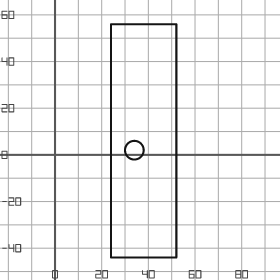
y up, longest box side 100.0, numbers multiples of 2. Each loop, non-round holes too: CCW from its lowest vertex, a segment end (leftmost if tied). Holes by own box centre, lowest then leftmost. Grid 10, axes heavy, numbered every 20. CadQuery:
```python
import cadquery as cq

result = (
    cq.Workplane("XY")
    .moveTo(24.0, -44.0)
    .lineTo(52.0, -44.0)
    .lineTo(52.0, 56.0)
    .lineTo(24.0, 56.0)
    .close()
    .moveTo(34.0, 2.0)
    .circle(4.0)
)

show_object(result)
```